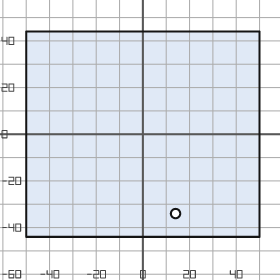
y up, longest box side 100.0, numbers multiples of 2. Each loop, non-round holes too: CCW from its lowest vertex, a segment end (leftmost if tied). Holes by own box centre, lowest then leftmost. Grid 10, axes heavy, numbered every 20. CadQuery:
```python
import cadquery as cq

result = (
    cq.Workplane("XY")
    .moveTo(-50.0, -44.0)
    .lineTo(50.0, -44.0)
    .lineTo(50.0, 44.0)
    .lineTo(-50.0, 44.0)
    .close()
    .moveTo(14.0, -34.0)
    .circle(2.0)
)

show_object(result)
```